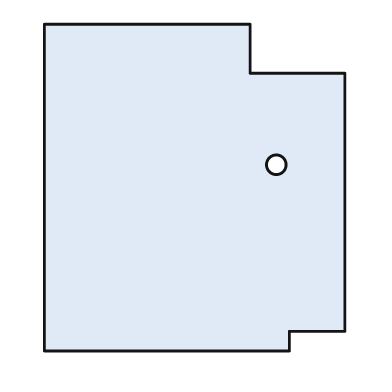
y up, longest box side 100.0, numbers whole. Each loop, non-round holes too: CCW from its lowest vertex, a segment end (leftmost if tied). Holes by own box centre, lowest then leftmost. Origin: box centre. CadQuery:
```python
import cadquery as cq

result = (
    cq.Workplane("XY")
    .moveTo(-46.0, -50.0)
    .lineTo(29.0, -50.0)
    .lineTo(29.0, -44.0)
    .lineTo(46.0, -44.0)
    .lineTo(46.0, 35.0)
    .lineTo(17.0, 35.0)
    .lineTo(17.0, 50.0)
    .lineTo(-46.0, 50.0)
    .close()
    .moveTo(25.0, 7.0)
    .circle(3.0)
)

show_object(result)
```